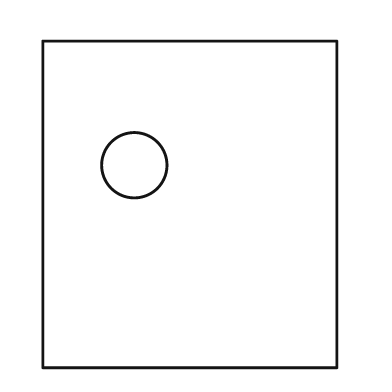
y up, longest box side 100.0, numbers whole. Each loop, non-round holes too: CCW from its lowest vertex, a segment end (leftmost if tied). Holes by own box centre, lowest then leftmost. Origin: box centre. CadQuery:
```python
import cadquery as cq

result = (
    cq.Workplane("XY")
    .moveTo(-45.0, -50.0)
    .lineTo(45.0, -50.0)
    .lineTo(45.0, 50.0)
    .lineTo(-45.0, 50.0)
    .close()
    .moveTo(-17.0, 12.0)
    .circle(10.0)
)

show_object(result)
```